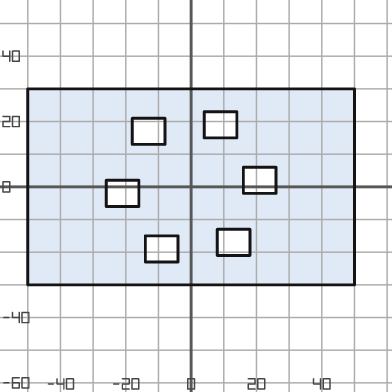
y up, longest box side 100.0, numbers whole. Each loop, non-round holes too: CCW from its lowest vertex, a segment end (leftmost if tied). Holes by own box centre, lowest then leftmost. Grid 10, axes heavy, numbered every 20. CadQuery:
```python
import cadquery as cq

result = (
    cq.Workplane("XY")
    .moveTo(-50.0, -30.0)
    .lineTo(50.0, -30.0)
    .lineTo(50.0, 30.0)
    .lineTo(-50.0, 30.0)
    .close()
    .moveTo(-14.0, -23.0)
    .lineTo(-4.0, -23.0)
    .lineTo(-4.0, -15.0)
    .lineTo(-14.0, -15.0)
    .close()
    .moveTo(8.0, -21.0)
    .lineTo(18.0, -21.0)
    .lineTo(18.0, -13.0)
    .lineTo(8.0, -13.0)
    .close()
    .moveTo(-26.0, -6.0)
    .lineTo(-16.0, -6.0)
    .lineTo(-16.0, 2.0)
    .lineTo(-26.0, 2.0)
    .close()
    .moveTo(16.0, -2.0)
    .lineTo(26.0, -2.0)
    .lineTo(26.0, 6.0)
    .lineTo(16.0, 6.0)
    .close()
    .moveTo(-18.0, 13.0)
    .lineTo(-8.0, 13.0)
    .lineTo(-8.0, 21.0)
    .lineTo(-18.0, 21.0)
    .close()
    .moveTo(4.0, 15.0)
    .lineTo(14.0, 15.0)
    .lineTo(14.0, 23.0)
    .lineTo(4.0, 23.0)
    .close()
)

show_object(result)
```